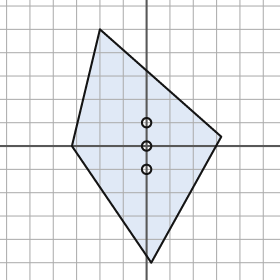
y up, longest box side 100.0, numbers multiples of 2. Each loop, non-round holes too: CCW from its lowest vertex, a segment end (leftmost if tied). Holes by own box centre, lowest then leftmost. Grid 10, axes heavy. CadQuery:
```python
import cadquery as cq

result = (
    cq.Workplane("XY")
    .moveTo(2.0, -50.0)
    .lineTo(32.0, 4.0)
    .lineTo(-20.0, 50.0)
    .lineTo(-32.0, 0.0)
    .close()
    .moveTo(0.0, -10.0)
    .circle(2.0)
    .moveTo(0.0, 0.0)
    .circle(2.0)
    .moveTo(0.0, 10.0)
    .circle(2.0)
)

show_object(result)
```